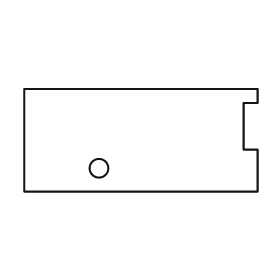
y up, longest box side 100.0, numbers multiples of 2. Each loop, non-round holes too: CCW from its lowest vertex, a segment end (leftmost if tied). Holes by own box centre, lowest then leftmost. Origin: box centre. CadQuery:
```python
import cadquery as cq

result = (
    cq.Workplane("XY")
    .moveTo(-50.0, -22.0)
    .lineTo(50.0, -22.0)
    .lineTo(50.0, -4.0)
    .lineTo(44.0, -4.0)
    .lineTo(44.0, 16.0)
    .lineTo(50.0, 16.0)
    .lineTo(50.0, 22.0)
    .lineTo(-50.0, 22.0)
    .close()
    .moveTo(-18.0, -12.0)
    .circle(4.0)
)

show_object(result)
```